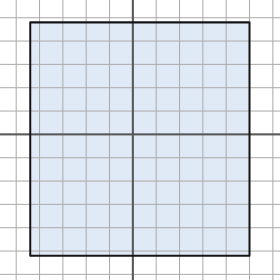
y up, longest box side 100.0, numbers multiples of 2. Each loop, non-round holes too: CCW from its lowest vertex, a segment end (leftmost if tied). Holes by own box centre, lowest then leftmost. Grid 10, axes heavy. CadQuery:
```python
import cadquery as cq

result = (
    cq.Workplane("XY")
    .moveTo(-44.0, -52.0)
    .lineTo(50.0, -52.0)
    .lineTo(50.0, 48.0)
    .lineTo(-44.0, 48.0)
    .close()
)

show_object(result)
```